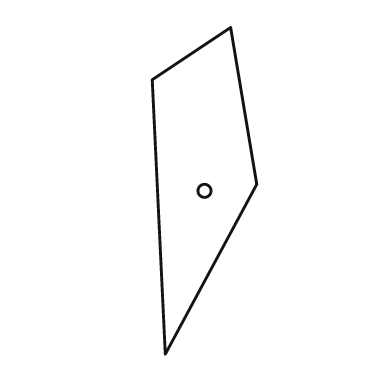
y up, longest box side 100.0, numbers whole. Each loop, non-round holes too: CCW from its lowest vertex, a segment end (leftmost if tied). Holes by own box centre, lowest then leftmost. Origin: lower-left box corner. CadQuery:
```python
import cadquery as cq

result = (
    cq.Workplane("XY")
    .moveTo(4.0, 0.0)
    .lineTo(32.0, 52.0)
    .lineTo(24.0, 100.0)
    .lineTo(0.0, 84.0)
    .close()
    .moveTo(16.0, 50.0)
    .circle(2.0)
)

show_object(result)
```